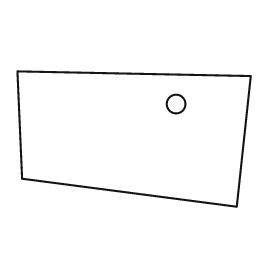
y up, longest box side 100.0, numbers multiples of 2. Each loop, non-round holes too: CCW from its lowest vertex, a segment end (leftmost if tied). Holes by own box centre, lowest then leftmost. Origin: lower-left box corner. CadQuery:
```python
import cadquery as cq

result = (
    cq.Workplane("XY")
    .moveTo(94.0, 0.0)
    .lineTo(100.0, 56.0)
    .lineTo(0.0, 58.0)
    .lineTo(2.0, 12.0)
    .close()
    .moveTo(68.0, 44.0)
    .circle(4.0)
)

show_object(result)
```